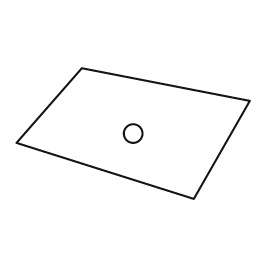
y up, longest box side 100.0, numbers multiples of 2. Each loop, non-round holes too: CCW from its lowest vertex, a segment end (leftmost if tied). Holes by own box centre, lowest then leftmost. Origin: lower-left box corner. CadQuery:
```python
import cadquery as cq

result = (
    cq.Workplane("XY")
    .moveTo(76.0, 0.0)
    .lineTo(100.0, 42.0)
    .lineTo(28.0, 56.0)
    .lineTo(0.0, 24.0)
    .close()
    .moveTo(50.0, 28.0)
    .circle(4.0)
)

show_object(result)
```